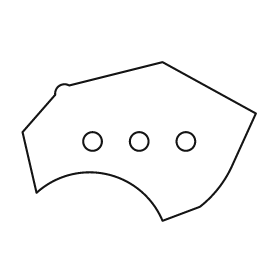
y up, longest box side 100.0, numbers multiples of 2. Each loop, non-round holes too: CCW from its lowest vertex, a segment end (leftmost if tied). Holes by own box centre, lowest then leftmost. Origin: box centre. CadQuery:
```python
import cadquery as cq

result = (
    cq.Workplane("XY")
    .moveTo(10.0, -34.0)
    .lineTo(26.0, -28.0)
    .threePointArc((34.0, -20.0), (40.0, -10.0))
    .lineTo(50.0, 12.0)
    .lineTo(10.0, 34.0)
    .lineTo(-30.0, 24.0)
    .threePointArc((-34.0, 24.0), (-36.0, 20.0))
    .lineTo(-50.0, 4.0)
    .lineTo(-44.0, -22.0)
    .threePointArc((-14.0, -14.0), (10.0, -34.0))
    .close()
    .moveTo(-20.0, 0.0)
    .circle(4.0)
    .moveTo(0.0, 0.0)
    .circle(4.0)
    .moveTo(20.0, 0.0)
    .circle(4.0)
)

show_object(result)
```